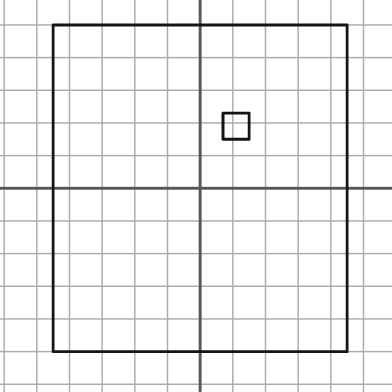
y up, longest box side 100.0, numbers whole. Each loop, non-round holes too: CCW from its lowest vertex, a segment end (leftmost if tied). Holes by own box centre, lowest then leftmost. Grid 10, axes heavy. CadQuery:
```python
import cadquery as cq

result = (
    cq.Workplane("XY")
    .moveTo(-45.0, -50.0)
    .lineTo(45.0, -50.0)
    .lineTo(45.0, 50.0)
    .lineTo(-45.0, 50.0)
    .close()
    .moveTo(7.0, 15.0)
    .lineTo(15.0, 15.0)
    .lineTo(15.0, 23.0)
    .lineTo(7.0, 23.0)
    .close()
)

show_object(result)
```